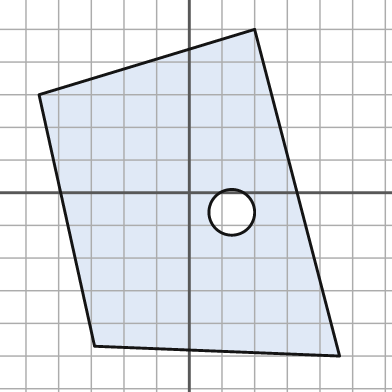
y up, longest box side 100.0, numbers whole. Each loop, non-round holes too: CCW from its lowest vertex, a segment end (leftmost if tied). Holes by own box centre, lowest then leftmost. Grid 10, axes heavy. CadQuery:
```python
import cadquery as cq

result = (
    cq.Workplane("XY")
    .moveTo(46.0, -50.0)
    .lineTo(20.0, 50.0)
    .lineTo(-46.0, 30.0)
    .lineTo(-29.0, -47.0)
    .close()
    .moveTo(13.0, -6.0)
    .circle(7.0)
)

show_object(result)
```